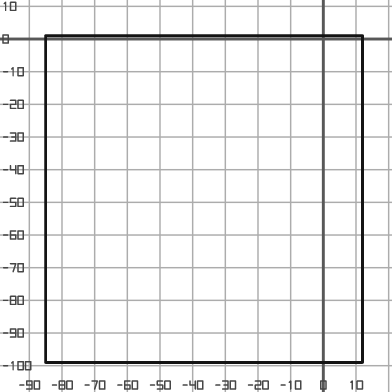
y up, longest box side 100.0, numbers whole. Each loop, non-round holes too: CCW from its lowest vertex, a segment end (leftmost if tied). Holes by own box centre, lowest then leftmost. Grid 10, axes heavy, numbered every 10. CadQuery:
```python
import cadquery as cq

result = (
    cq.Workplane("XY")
    .moveTo(-85.0, -99.0)
    .lineTo(12.0, -99.0)
    .lineTo(12.0, 1.0)
    .lineTo(-85.0, 1.0)
    .close()
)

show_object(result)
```